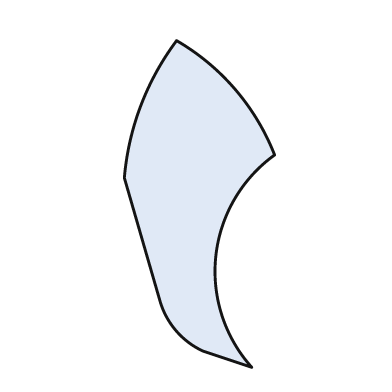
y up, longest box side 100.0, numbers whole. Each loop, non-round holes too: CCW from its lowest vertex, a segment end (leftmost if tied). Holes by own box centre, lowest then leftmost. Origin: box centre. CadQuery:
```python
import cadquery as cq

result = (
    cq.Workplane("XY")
    .moveTo(16.0, -50.0)
    .threePointArc((5.0, -16.0), (23.0, 15.0))
    .threePointArc((11.0, 35.0), (-7.0, 50.0))
    .threePointArc((-18.0, 30.0), (-23.0, 8.0))
    .lineTo(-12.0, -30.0)
    .threePointArc((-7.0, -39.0), (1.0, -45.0))
    .close()
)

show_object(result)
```